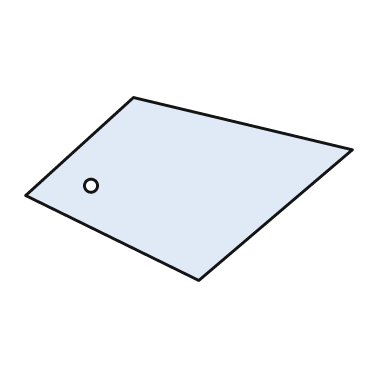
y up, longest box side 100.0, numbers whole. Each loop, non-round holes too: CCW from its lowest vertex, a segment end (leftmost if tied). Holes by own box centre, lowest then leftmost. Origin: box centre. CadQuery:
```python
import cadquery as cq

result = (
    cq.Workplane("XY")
    .moveTo(3.0, -28.0)
    .lineTo(50.0, 12.0)
    .lineTo(-17.0, 28.0)
    .lineTo(-50.0, -2.0)
    .close()
    .moveTo(-30.0, 1.0)
    .circle(2.0)
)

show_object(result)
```